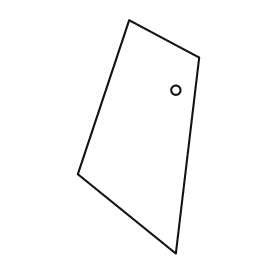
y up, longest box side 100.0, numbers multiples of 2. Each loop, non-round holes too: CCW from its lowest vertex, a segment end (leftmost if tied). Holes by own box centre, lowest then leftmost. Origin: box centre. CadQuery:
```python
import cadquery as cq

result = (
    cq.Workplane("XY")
    .moveTo(16.0, -50.0)
    .lineTo(26.0, 34.0)
    .lineTo(-4.0, 50.0)
    .lineTo(-26.0, -16.0)
    .close()
    .moveTo(16.0, 20.0)
    .circle(2.0)
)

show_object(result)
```